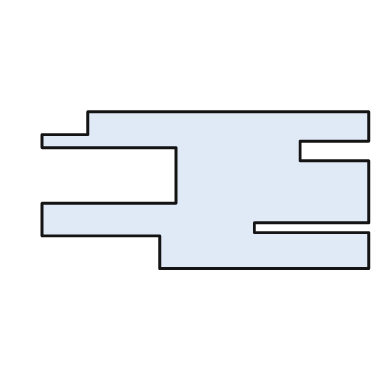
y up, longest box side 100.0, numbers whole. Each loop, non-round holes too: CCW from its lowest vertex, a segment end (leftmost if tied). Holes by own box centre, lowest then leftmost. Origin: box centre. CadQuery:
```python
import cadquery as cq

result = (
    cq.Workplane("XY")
    .moveTo(-14.0, -24.0)
    .lineTo(50.0, -24.0)
    .lineTo(50.0, -13.0)
    .lineTo(15.0, -13.0)
    .lineTo(15.0, -10.0)
    .lineTo(50.0, -10.0)
    .lineTo(50.0, 9.0)
    .lineTo(29.0, 9.0)
    .lineTo(29.0, 15.0)
    .lineTo(50.0, 15.0)
    .lineTo(50.0, 24.0)
    .lineTo(-36.0, 24.0)
    .lineTo(-36.0, 17.0)
    .lineTo(-50.0, 17.0)
    .lineTo(-50.0, 13.0)
    .lineTo(-9.0, 13.0)
    .lineTo(-9.0, -4.0)
    .lineTo(-50.0, -4.0)
    .lineTo(-50.0, -14.0)
    .lineTo(-14.0, -14.0)
    .close()
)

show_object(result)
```